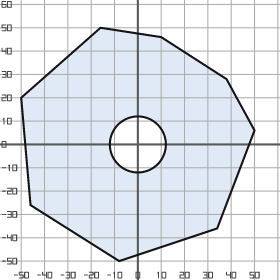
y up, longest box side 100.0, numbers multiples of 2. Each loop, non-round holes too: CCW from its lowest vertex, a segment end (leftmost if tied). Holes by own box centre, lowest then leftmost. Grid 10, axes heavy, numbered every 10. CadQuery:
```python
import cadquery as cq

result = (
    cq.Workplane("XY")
    .moveTo(-8.0, -50.0)
    .lineTo(34.0, -36.0)
    .lineTo(50.0, 6.0)
    .lineTo(38.0, 28.0)
    .lineTo(10.0, 46.0)
    .lineTo(-16.0, 50.0)
    .lineTo(-50.0, 20.0)
    .lineTo(-46.0, -26.0)
    .close()
    .moveTo(0.0, 0.0)
    .circle(12.0)
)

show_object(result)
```